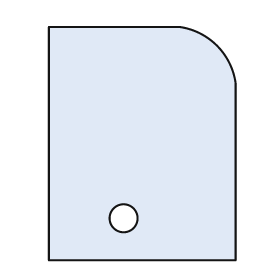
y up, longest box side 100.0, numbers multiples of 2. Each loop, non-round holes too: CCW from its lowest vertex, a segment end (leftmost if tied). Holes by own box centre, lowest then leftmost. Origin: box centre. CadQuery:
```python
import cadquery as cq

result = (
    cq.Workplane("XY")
    .moveTo(-40.0, -50.0)
    .lineTo(40.0, -50.0)
    .lineTo(40.0, 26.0)
    .threePointArc((32.0, 42.0), (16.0, 50.0))
    .lineTo(-40.0, 50.0)
    .close()
    .moveTo(-8.0, -32.0)
    .circle(6.0)
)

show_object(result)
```